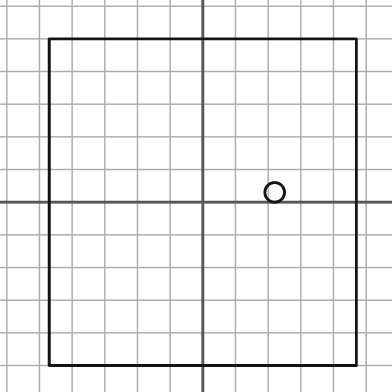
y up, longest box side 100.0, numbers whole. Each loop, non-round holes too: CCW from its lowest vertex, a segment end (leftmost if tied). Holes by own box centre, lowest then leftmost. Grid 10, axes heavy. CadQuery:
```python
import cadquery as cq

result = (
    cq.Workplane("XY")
    .moveTo(-47.0, -50.0)
    .lineTo(47.0, -50.0)
    .lineTo(47.0, 50.0)
    .lineTo(-47.0, 50.0)
    .close()
    .moveTo(22.0, 3.0)
    .circle(3.0)
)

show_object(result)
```